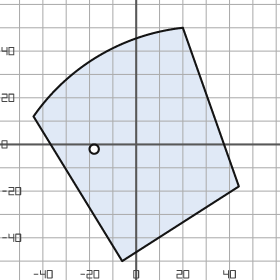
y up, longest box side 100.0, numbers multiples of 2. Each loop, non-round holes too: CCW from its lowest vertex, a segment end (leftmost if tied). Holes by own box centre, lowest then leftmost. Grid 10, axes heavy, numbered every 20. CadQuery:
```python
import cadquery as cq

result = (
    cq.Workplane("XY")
    .moveTo(-6.0, -50.0)
    .lineTo(44.0, -18.0)
    .lineTo(20.0, 50.0)
    .threePointArc((-16.0, 38.0), (-44.0, 12.0))
    .close()
    .moveTo(-18.0, -2.0)
    .circle(2.0)
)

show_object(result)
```